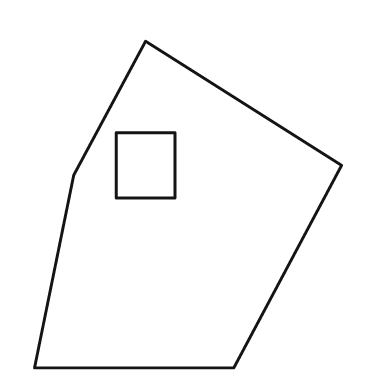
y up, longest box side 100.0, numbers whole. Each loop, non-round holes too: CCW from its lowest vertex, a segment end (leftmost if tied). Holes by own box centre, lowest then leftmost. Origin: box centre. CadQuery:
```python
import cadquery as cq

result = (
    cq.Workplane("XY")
    .moveTo(-47.0, -50.0)
    .lineTo(14.0, -50.0)
    .lineTo(47.0, 12.0)
    .lineTo(-13.0, 50.0)
    .lineTo(-35.0, 9.0)
    .close()
    .moveTo(-22.0, 2.0)
    .lineTo(-4.0, 2.0)
    .lineTo(-4.0, 22.0)
    .lineTo(-22.0, 22.0)
    .close()
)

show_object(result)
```